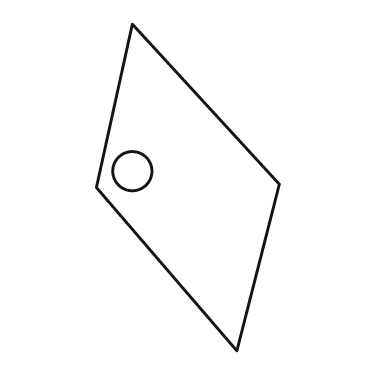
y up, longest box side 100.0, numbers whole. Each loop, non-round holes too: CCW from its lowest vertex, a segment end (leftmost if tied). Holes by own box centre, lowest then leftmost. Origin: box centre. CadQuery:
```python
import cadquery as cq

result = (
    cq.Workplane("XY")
    .moveTo(15.0, -50.0)
    .lineTo(28.0, 1.0)
    .lineTo(-17.0, 50.0)
    .lineTo(-28.0, 0.0)
    .close()
    .moveTo(-17.0, 5.0)
    .circle(6.0)
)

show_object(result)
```